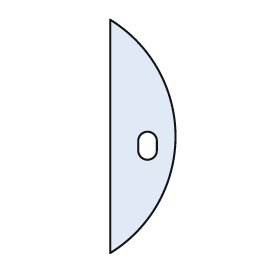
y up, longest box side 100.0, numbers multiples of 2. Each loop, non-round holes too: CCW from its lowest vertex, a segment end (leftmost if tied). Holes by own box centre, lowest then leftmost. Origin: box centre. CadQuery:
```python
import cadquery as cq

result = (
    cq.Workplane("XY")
    .moveTo(-14.0, -50.0)
    .threePointArc((14.0, 0.0), (-14.0, 50.0))
    .close()
    .moveTo(-2.0, -6.0)
    .threePointArc((2.0, -10.0), (6.0, -6.0))
    .lineTo(6.0, -2.0)
    .threePointArc((2.0, 2.0), (-2.0, -2.0))
    .close()
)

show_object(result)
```